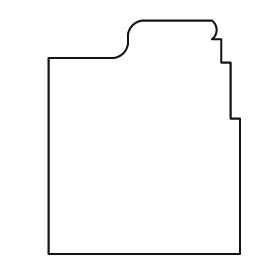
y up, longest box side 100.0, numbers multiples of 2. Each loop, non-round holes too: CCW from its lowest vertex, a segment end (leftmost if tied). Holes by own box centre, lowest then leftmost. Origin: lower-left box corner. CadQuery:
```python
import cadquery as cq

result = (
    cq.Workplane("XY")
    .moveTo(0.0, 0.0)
    .lineTo(82.0, 0.0)
    .lineTo(82.0, 58.0)
    .lineTo(78.0, 58.0)
    .lineTo(78.0, 82.0)
    .lineTo(74.0, 82.0)
    .lineTo(74.0, 92.0)
    .lineTo(70.0, 92.0)
    .threePointArc((72.0, 96.0), (70.0, 100.0))
    .lineTo(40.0, 100.0)
    .threePointArc((36.0, 98.0), (34.0, 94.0))
    .lineTo(34.0, 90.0)
    .threePointArc((32.0, 86.0), (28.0, 84.0))
    .lineTo(0.0, 84.0)
    .close()
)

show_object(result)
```